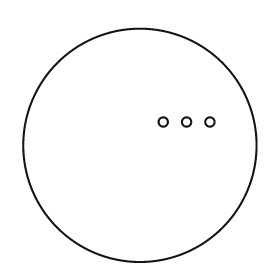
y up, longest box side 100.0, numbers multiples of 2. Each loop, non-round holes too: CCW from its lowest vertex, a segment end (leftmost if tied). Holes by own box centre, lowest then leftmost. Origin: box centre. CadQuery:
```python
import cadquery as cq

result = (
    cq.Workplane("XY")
    .moveTo(0.0, 0.0)
    .circle(50.0)
    .moveTo(10.0, 10.0)
    .circle(2.0)
    .moveTo(20.0, 10.0)
    .circle(2.0)
    .moveTo(30.0, 10.0)
    .circle(2.0)
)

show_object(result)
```